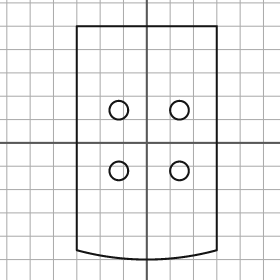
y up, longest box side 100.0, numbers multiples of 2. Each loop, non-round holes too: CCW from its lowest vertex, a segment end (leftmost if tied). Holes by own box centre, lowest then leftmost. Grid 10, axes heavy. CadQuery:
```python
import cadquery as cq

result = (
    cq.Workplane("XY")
    .moveTo(-30.0, -46.0)
    .threePointArc((0.0, -50.0), (30.0, -46.0))
    .lineTo(30.0, 50.0)
    .lineTo(-30.0, 50.0)
    .close()
    .moveTo(-12.0, -12.0)
    .circle(4.0)
    .moveTo(14.0, -12.0)
    .circle(4.0)
    .moveTo(-12.0, 14.0)
    .circle(4.0)
    .moveTo(14.0, 14.0)
    .circle(4.0)
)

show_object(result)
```